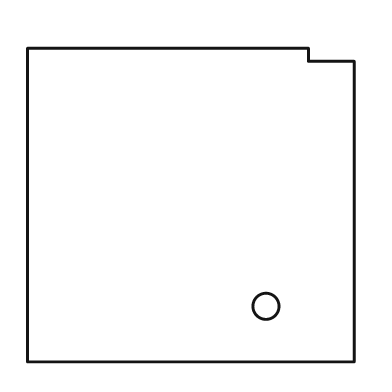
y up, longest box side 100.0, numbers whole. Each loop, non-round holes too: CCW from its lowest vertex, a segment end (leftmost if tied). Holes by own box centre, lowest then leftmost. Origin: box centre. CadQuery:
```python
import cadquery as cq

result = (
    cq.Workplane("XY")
    .moveTo(-50.0, -48.0)
    .lineTo(50.0, -48.0)
    .lineTo(50.0, 44.0)
    .lineTo(36.0, 44.0)
    .lineTo(36.0, 48.0)
    .lineTo(-50.0, 48.0)
    .close()
    .moveTo(23.0, -31.0)
    .circle(4.0)
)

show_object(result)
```